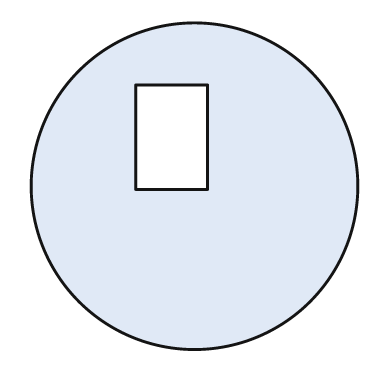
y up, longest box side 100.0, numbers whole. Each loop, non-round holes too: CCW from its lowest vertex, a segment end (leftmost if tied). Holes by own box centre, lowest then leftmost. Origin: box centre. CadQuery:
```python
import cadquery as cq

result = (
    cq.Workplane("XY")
    .moveTo(0.0, 0.0)
    .circle(50.0)
    .moveTo(-18.0, -1.0)
    .lineTo(4.0, -1.0)
    .lineTo(4.0, 31.0)
    .lineTo(-18.0, 31.0)
    .close()
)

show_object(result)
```